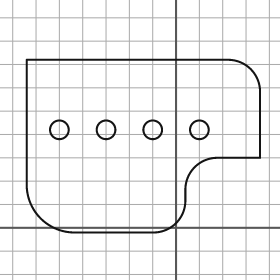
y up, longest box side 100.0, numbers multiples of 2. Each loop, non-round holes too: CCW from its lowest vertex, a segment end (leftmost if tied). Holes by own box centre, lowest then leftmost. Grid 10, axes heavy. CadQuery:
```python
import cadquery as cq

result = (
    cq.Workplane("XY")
    .moveTo(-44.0, -2.0)
    .lineTo(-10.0, -2.0)
    .threePointArc((0.0, 2.0), (4.0, 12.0))
    .lineTo(4.0, 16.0)
    .threePointArc((8.0, 26.0), (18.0, 30.0))
    .lineTo(36.0, 30.0)
    .lineTo(36.0, 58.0)
    .threePointArc((32.0, 68.0), (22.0, 72.0))
    .lineTo(-64.0, 72.0)
    .lineTo(-64.0, 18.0)
    .threePointArc((-58.0, 4.0), (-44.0, -2.0))
    .close()
    .moveTo(-50.0, 42.0)
    .circle(4.0)
    .moveTo(-30.0, 42.0)
    .circle(4.0)
    .moveTo(-10.0, 42.0)
    .circle(4.0)
    .moveTo(10.0, 42.0)
    .circle(4.0)
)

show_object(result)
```